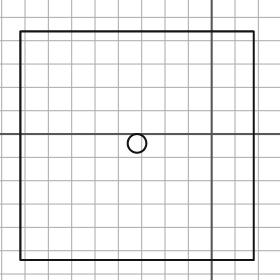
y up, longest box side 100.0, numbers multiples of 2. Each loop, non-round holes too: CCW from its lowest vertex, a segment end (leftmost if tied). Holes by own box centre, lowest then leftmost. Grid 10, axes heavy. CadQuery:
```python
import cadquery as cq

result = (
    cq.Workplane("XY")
    .moveTo(-82.0, -54.0)
    .lineTo(18.0, -54.0)
    .lineTo(18.0, 44.0)
    .lineTo(-82.0, 44.0)
    .close()
    .moveTo(-32.0, -4.0)
    .circle(4.0)
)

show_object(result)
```